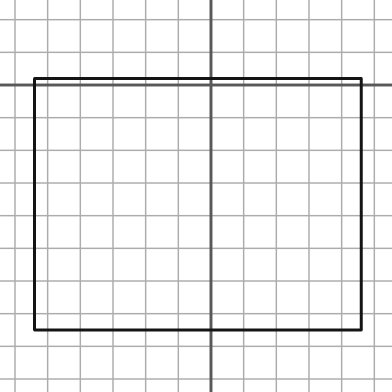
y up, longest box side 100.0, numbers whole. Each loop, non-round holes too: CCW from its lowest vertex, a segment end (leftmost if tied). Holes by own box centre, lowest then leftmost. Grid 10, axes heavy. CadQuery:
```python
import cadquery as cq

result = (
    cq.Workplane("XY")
    .moveTo(-54.0, -75.0)
    .lineTo(46.0, -75.0)
    .lineTo(46.0, 2.0)
    .lineTo(-54.0, 2.0)
    .close()
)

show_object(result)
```